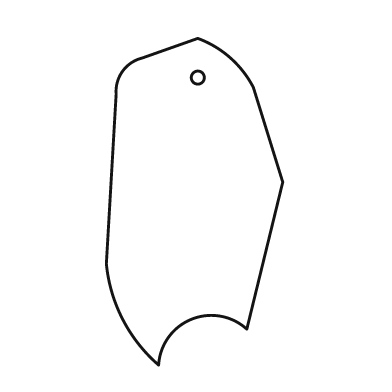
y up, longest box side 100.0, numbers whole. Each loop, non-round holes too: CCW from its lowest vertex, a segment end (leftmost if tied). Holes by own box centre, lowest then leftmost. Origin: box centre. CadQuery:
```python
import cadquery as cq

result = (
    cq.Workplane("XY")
    .moveTo(-11.0, -50.0)
    .threePointArc((-1.0, -36.0), (16.0, -39.0))
    .lineTo(27.0, 6.0)
    .lineTo(18.0, 35.0)
    .threePointArc((11.0, 44.0), (1.0, 50.0))
    .lineTo(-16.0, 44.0)
    .threePointArc((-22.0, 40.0), (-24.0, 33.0))
    .lineTo(-27.0, -19.0)
    .threePointArc((-22.0, -36.0), (-11.0, -50.0))
    .close()
    .moveTo(1.0, 38.0)
    .circle(2.0)
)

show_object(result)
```